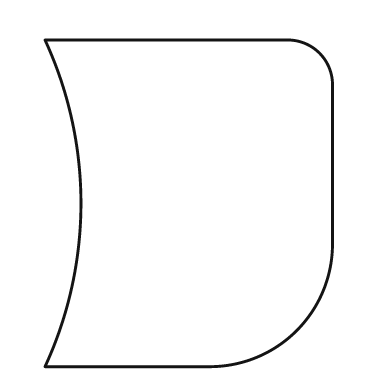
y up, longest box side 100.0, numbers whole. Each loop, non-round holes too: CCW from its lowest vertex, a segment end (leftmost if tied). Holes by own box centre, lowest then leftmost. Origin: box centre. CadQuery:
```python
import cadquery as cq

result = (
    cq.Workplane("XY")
    .moveTo(-44.0, -50.0)
    .lineTo(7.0, -50.0)
    .threePointArc((33.0, -39.0), (44.0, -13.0))
    .lineTo(44.0, 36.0)
    .threePointArc((40.0, 46.0), (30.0, 50.0))
    .lineTo(-44.0, 50.0)
    .threePointArc((-33.0, 0.0), (-44.0, -50.0))
    .close()
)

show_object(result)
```